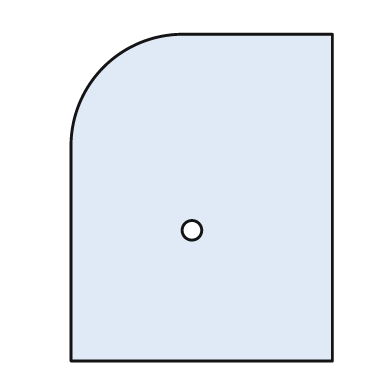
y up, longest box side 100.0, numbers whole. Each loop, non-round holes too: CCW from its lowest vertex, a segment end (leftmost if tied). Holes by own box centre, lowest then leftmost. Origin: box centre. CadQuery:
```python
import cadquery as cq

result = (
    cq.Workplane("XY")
    .moveTo(-40.0, -50.0)
    .lineTo(40.0, -50.0)
    .lineTo(40.0, 50.0)
    .lineTo(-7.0, 50.0)
    .threePointArc((-30.0, 40.0), (-40.0, 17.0))
    .close()
    .moveTo(-3.0, -10.0)
    .circle(3.0)
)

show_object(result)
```